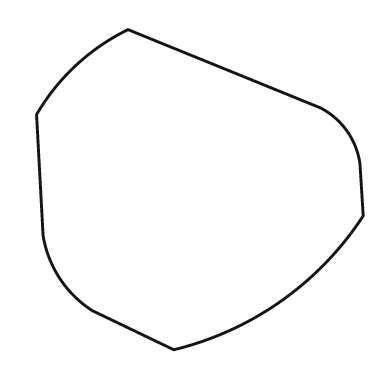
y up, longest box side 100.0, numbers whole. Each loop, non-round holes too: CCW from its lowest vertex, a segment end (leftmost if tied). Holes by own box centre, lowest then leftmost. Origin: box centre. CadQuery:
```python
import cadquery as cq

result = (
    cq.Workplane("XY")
    .moveTo(-8.0, -49.0)
    .threePointArc((25.0, -34.0), (50.0, -8.0))
    .lineTo(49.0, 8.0)
    .threePointArc((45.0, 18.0), (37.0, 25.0))
    .lineTo(-22.0, 49.0)
    .threePointArc((-38.0, 38.0), (-50.0, 23.0))
    .lineTo(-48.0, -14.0)
    .threePointArc((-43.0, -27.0), (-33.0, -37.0))
    .close()
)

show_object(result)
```